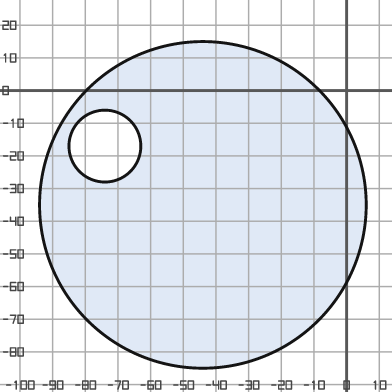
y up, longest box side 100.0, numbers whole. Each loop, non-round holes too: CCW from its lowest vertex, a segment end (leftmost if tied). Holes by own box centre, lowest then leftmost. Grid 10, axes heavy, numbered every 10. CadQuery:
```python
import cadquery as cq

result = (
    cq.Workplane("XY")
    .moveTo(-44.0, -35.0)
    .circle(50.0)
    .moveTo(-74.0, -17.0)
    .circle(11.0)
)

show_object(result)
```